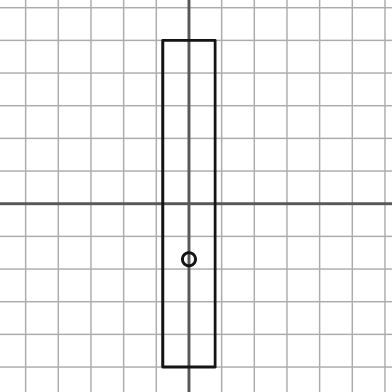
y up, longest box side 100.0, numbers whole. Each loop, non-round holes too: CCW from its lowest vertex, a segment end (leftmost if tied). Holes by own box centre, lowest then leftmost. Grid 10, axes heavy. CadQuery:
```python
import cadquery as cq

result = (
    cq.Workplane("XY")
    .moveTo(-8.0, -50.0)
    .lineTo(8.0, -50.0)
    .lineTo(8.0, 50.0)
    .lineTo(-8.0, 50.0)
    .close()
    .moveTo(0.0, -17.0)
    .circle(2.0)
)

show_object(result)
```